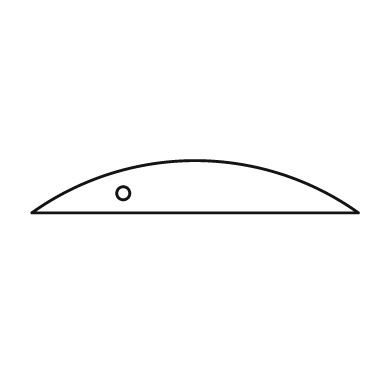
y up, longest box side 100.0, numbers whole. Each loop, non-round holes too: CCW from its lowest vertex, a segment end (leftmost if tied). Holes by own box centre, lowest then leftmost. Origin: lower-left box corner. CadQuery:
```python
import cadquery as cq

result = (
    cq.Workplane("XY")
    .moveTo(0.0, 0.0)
    .lineTo(100.0, 0.0)
    .threePointArc((50.0, 16.0), (0.0, 0.0))
    .close()
    .moveTo(28.0, 6.0)
    .circle(2.0)
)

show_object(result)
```